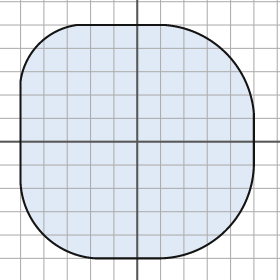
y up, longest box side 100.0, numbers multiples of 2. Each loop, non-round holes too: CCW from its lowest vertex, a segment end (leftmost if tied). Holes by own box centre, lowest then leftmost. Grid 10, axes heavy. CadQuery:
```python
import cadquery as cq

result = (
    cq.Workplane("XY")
    .moveTo(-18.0, -50.0)
    .lineTo(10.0, -50.0)
    .threePointArc((38.0, -38.0), (50.0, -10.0))
    .lineTo(50.0, 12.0)
    .threePointArc((38.0, 38.0), (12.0, 50.0))
    .lineTo(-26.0, 50.0)
    .threePointArc((-42.0, 42.0), (-50.0, 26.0))
    .lineTo(-50.0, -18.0)
    .threePointArc((-40.0, -40.0), (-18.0, -50.0))
    .close()
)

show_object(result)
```